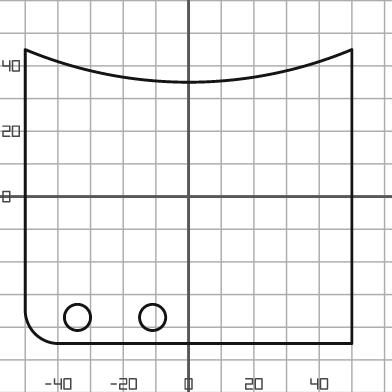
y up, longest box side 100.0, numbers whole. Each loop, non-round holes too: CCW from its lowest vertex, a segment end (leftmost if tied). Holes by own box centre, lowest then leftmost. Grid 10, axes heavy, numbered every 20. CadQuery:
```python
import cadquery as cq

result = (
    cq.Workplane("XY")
    .moveTo(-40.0, -45.0)
    .lineTo(50.0, -45.0)
    .lineTo(50.0, 45.0)
    .threePointArc((0.0, 35.0), (-50.0, 45.0))
    .lineTo(-50.0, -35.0)
    .threePointArc((-47.0, -42.0), (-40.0, -45.0))
    .close()
    .moveTo(-34.0, -37.0)
    .circle(4.0)
    .moveTo(-11.0, -37.0)
    .circle(4.0)
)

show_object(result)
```